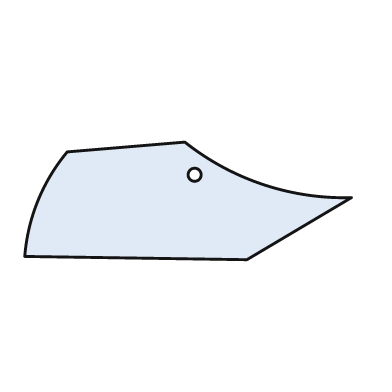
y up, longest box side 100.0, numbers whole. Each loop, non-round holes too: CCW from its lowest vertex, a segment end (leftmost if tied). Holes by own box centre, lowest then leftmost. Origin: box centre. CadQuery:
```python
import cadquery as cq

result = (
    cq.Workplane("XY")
    .moveTo(18.0, -18.0)
    .lineTo(50.0, 1.0)
    .threePointArc((23.0, 5.0), (-1.0, 18.0))
    .lineTo(-37.0, 15.0)
    .threePointArc((-46.0, 0.0), (-50.0, -17.0))
    .close()
    .moveTo(2.0, 8.0)
    .circle(2.0)
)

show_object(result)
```